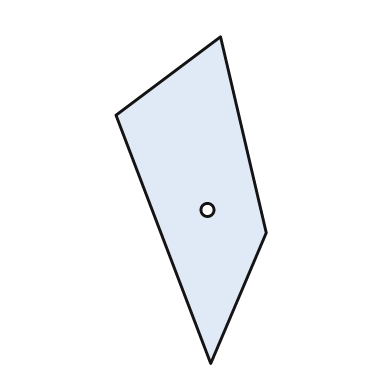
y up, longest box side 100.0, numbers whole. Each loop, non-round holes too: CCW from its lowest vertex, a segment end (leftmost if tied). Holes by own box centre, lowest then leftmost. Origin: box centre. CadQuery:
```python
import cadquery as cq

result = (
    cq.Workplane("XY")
    .moveTo(6.0, -50.0)
    .lineTo(23.0, -10.0)
    .lineTo(9.0, 50.0)
    .lineTo(-23.0, 26.0)
    .close()
    .moveTo(5.0, -3.0)
    .circle(2.0)
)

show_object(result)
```